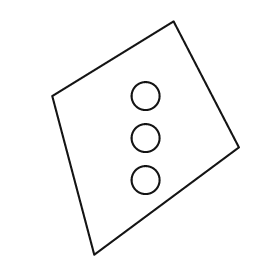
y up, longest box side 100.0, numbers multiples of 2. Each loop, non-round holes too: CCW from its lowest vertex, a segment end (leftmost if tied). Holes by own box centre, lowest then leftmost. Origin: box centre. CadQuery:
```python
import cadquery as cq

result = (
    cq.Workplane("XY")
    .moveTo(-22.0, -50.0)
    .lineTo(40.0, -4.0)
    .lineTo(12.0, 50.0)
    .lineTo(-40.0, 18.0)
    .close()
    .moveTo(0.0, -18.0)
    .circle(6.0)
    .moveTo(0.0, 0.0)
    .circle(6.0)
    .moveTo(0.0, 18.0)
    .circle(6.0)
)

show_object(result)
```